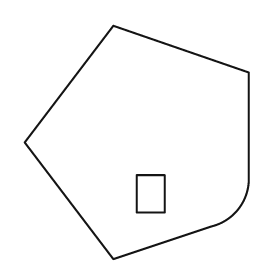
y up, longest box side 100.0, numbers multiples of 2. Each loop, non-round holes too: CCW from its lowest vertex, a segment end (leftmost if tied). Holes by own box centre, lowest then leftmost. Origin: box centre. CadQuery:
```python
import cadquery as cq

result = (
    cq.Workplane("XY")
    .moveTo(-10.0, -50.0)
    .lineTo(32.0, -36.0)
    .threePointArc((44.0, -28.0), (48.0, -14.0))
    .lineTo(48.0, 30.0)
    .lineTo(-10.0, 50.0)
    .lineTo(-48.0, 0.0)
    .close()
    .moveTo(0.0, -30.0)
    .lineTo(12.0, -30.0)
    .lineTo(12.0, -14.0)
    .lineTo(0.0, -14.0)
    .close()
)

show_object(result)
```